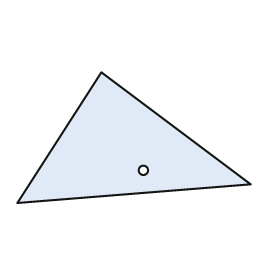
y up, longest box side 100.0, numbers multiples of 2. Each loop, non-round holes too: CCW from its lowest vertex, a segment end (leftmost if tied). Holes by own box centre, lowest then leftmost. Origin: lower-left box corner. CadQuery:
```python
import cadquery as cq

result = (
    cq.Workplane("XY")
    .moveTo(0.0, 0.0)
    .lineTo(100.0, 8.0)
    .lineTo(36.0, 56.0)
    .close()
    .moveTo(54.0, 14.0)
    .circle(2.0)
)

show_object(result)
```